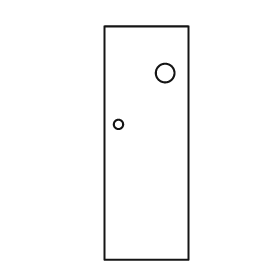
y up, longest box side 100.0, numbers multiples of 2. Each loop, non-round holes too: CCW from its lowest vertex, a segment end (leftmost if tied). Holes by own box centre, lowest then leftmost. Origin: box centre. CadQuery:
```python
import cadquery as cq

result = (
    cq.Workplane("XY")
    .moveTo(-18.0, -50.0)
    .lineTo(18.0, -50.0)
    .lineTo(18.0, 50.0)
    .lineTo(-18.0, 50.0)
    .close()
    .moveTo(-12.0, 8.0)
    .circle(2.0)
    .moveTo(8.0, 30.0)
    .circle(4.0)
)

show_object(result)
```